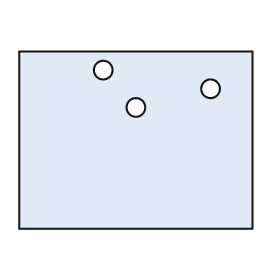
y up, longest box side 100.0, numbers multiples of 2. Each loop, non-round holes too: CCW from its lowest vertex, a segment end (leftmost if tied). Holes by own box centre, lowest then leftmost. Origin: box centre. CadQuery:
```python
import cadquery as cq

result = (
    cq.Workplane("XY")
    .moveTo(-50.0, -38.0)
    .lineTo(50.0, -38.0)
    .lineTo(50.0, 38.0)
    .lineTo(-50.0, 38.0)
    .close()
    .moveTo(0.0, 14.0)
    .circle(4.0)
    .moveTo(32.0, 22.0)
    .circle(4.0)
    .moveTo(-14.0, 30.0)
    .circle(4.0)
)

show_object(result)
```